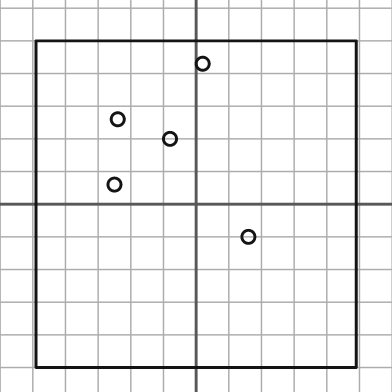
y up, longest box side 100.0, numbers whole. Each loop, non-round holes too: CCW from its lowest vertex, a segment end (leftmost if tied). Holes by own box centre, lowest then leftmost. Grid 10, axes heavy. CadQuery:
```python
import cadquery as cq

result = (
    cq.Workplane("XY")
    .moveTo(-49.0, -50.0)
    .lineTo(49.0, -50.0)
    .lineTo(49.0, 50.0)
    .lineTo(-49.0, 50.0)
    .close()
    .moveTo(16.0, -10.0)
    .circle(2.0)
    .moveTo(-25.0, 6.0)
    .circle(2.0)
    .moveTo(-8.0, 20.0)
    .circle(2.0)
    .moveTo(-24.0, 26.0)
    .circle(2.0)
    .moveTo(2.0, 43.0)
    .circle(2.0)
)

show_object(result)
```